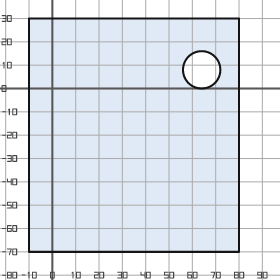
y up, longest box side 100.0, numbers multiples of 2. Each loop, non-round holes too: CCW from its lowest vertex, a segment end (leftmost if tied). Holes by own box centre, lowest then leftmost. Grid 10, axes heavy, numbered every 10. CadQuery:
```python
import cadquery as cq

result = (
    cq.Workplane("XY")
    .moveTo(-10.0, -70.0)
    .lineTo(80.0, -70.0)
    .lineTo(80.0, 30.0)
    .lineTo(-10.0, 30.0)
    .close()
    .moveTo(64.0, 8.0)
    .circle(8.0)
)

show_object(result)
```